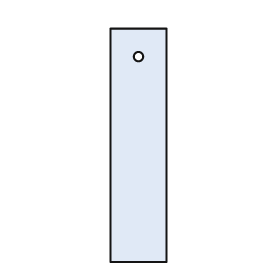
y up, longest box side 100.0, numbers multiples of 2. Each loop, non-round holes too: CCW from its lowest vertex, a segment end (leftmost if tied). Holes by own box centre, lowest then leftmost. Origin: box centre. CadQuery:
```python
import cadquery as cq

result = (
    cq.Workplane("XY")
    .moveTo(-12.0, -50.0)
    .lineTo(12.0, -50.0)
    .lineTo(12.0, 50.0)
    .lineTo(-12.0, 50.0)
    .close()
    .moveTo(0.0, 38.0)
    .circle(2.0)
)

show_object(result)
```